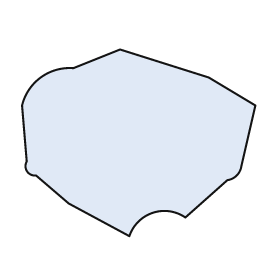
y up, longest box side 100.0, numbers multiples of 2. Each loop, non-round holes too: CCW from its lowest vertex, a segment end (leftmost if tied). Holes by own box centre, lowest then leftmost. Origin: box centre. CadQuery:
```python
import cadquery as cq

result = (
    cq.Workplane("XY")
    .moveTo(-4.0, -40.0)
    .threePointArc((6.0, -30.0), (20.0, -32.0))
    .lineTo(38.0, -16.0)
    .threePointArc((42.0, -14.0), (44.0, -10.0))
    .lineTo(50.0, 16.0)
    .lineTo(30.0, 28.0)
    .lineTo(-8.0, 40.0)
    .lineTo(-28.0, 32.0)
    .threePointArc((-42.0, 28.0), (-50.0, 16.0))
    .lineTo(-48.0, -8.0)
    .threePointArc((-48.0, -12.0), (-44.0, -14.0))
    .lineTo(-30.0, -26.0)
    .close()
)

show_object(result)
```